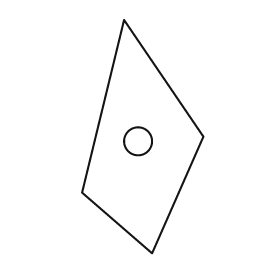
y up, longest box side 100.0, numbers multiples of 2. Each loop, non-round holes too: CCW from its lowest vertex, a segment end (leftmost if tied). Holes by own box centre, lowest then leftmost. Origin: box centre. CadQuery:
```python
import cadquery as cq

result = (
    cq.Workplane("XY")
    .moveTo(4.0, -50.0)
    .lineTo(26.0, 0.0)
    .lineTo(-8.0, 50.0)
    .lineTo(-26.0, -24.0)
    .close()
    .moveTo(-2.0, -2.0)
    .circle(6.0)
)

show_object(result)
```